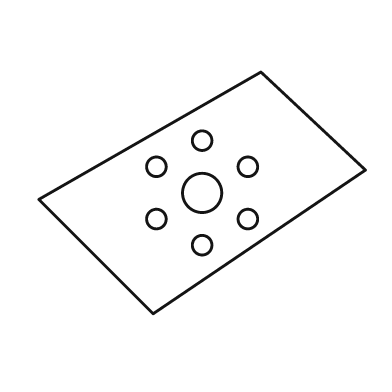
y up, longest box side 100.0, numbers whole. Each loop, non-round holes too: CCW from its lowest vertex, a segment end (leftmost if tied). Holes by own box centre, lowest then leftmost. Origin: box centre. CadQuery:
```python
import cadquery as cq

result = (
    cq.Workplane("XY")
    .moveTo(-15.0, -37.0)
    .lineTo(50.0, 7.0)
    .lineTo(18.0, 37.0)
    .lineTo(-50.0, -2.0)
    .close()
    .moveTo(0.0, -16.0)
    .circle(3.0)
    .moveTo(-14.0, -8.0)
    .circle(3.0)
    .moveTo(14.0, -8.0)
    .circle(3.0)
    .moveTo(0.0, 0.0)
    .circle(6.0)
    .moveTo(-14.0, 8.0)
    .circle(3.0)
    .moveTo(14.0, 8.0)
    .circle(3.0)
    .moveTo(0.0, 16.0)
    .circle(3.0)
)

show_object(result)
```